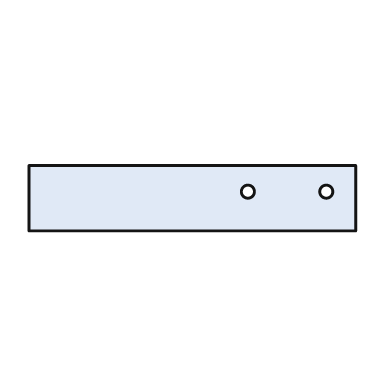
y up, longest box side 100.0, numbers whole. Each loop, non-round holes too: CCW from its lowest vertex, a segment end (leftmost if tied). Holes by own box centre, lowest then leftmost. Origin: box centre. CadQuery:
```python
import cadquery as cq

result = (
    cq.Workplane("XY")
    .moveTo(-50.0, -10.0)
    .lineTo(50.0, -10.0)
    .lineTo(50.0, 10.0)
    .lineTo(-50.0, 10.0)
    .close()
    .moveTo(17.0, 2.0)
    .circle(2.0)
    .moveTo(41.0, 2.0)
    .circle(2.0)
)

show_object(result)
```